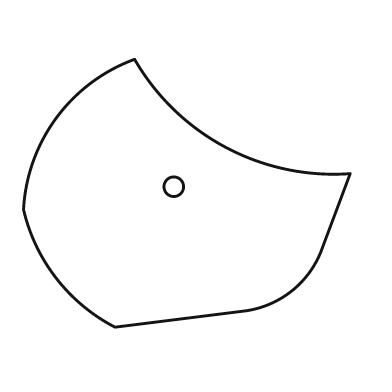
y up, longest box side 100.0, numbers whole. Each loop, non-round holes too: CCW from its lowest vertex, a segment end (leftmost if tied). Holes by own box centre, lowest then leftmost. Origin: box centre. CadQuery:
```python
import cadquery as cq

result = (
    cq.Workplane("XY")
    .moveTo(-22.0, -41.0)
    .lineTo(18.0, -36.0)
    .threePointArc((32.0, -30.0), (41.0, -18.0))
    .lineTo(50.0, 6.0)
    .threePointArc((12.0, 14.0), (-16.0, 41.0))
    .threePointArc((-40.0, 23.0), (-50.0, -5.0))
    .threePointArc((-40.0, -26.0), (-22.0, -41.0))
    .close()
    .moveTo(-4.0, 2.0)
    .circle(3.0)
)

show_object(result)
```